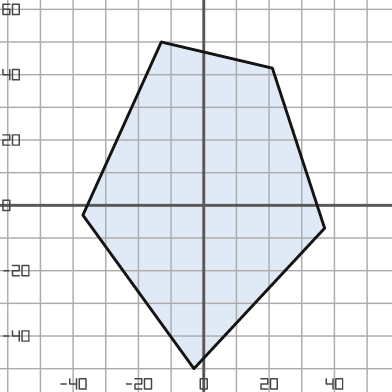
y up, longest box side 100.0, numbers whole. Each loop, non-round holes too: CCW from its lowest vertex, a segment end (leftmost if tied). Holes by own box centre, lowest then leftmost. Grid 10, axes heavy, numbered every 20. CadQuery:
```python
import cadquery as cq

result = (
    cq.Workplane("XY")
    .moveTo(-3.0, -50.0)
    .lineTo(37.0, -7.0)
    .lineTo(21.0, 42.0)
    .lineTo(-13.0, 50.0)
    .lineTo(-37.0, -3.0)
    .close()
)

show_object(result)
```